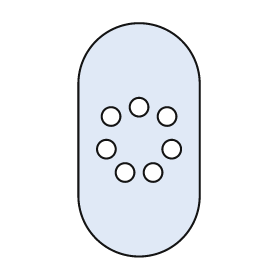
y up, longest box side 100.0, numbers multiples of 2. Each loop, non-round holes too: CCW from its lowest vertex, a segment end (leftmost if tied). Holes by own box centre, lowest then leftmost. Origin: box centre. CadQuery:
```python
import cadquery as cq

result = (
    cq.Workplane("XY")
    .moveTo(-26.0, -24.0)
    .threePointArc((0.0, -50.0), (26.0, -24.0))
    .lineTo(26.0, 24.0)
    .threePointArc((0.0, 50.0), (-26.0, 24.0))
    .close()
    .moveTo(-6.0, -14.0)
    .circle(4.0)
    .moveTo(6.0, -14.0)
    .circle(4.0)
    .moveTo(-14.0, -4.0)
    .circle(4.0)
    .moveTo(14.0, -4.0)
    .circle(4.0)
    .moveTo(-12.0, 10.0)
    .circle(4.0)
    .moveTo(12.0, 10.0)
    .circle(4.0)
    .moveTo(0.0, 14.0)
    .circle(4.0)
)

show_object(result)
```